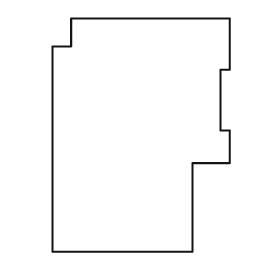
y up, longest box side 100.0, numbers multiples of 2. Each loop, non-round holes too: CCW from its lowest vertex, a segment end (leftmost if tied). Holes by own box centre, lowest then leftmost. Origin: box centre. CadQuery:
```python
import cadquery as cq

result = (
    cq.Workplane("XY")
    .moveTo(-38.0, -50.0)
    .lineTo(22.0, -50.0)
    .lineTo(22.0, -12.0)
    .lineTo(38.0, -12.0)
    .lineTo(38.0, 2.0)
    .lineTo(34.0, 2.0)
    .lineTo(34.0, 28.0)
    .lineTo(38.0, 28.0)
    .lineTo(38.0, 50.0)
    .lineTo(-30.0, 50.0)
    .lineTo(-30.0, 38.0)
    .lineTo(-38.0, 38.0)
    .close()
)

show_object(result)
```